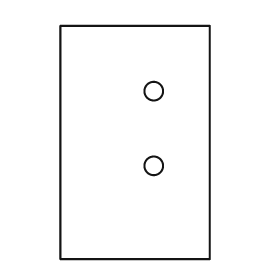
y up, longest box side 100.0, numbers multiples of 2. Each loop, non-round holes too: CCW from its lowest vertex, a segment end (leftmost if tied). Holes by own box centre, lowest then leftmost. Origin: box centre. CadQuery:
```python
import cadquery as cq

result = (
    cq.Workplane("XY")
    .moveTo(-32.0, -50.0)
    .lineTo(32.0, -50.0)
    .lineTo(32.0, 50.0)
    .lineTo(-32.0, 50.0)
    .close()
    .moveTo(8.0, -10.0)
    .circle(4.0)
    .moveTo(8.0, 22.0)
    .circle(4.0)
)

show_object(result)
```